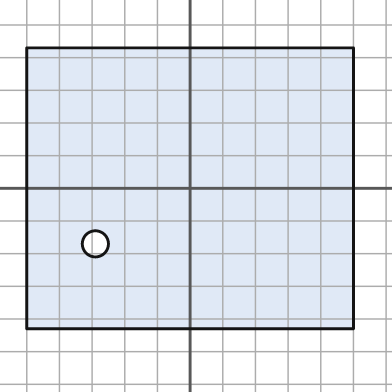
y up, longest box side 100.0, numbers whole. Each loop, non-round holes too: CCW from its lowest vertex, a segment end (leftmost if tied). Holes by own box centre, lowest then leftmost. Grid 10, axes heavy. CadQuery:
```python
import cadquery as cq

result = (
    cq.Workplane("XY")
    .moveTo(-50.0, -43.0)
    .lineTo(50.0, -43.0)
    .lineTo(50.0, 43.0)
    .lineTo(-50.0, 43.0)
    .close()
    .moveTo(-29.0, -17.0)
    .circle(4.0)
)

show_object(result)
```